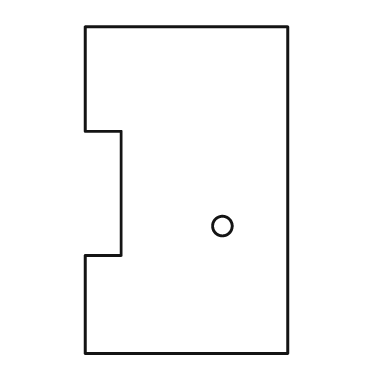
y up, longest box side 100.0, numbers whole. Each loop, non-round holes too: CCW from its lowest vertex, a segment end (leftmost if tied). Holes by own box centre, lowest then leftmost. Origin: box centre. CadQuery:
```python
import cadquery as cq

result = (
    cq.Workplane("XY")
    .moveTo(-31.0, -50.0)
    .lineTo(31.0, -50.0)
    .lineTo(31.0, 50.0)
    .lineTo(-31.0, 50.0)
    .lineTo(-31.0, 18.0)
    .lineTo(-20.0, 18.0)
    .lineTo(-20.0, -20.0)
    .lineTo(-31.0, -20.0)
    .close()
    .moveTo(11.0, -11.0)
    .circle(3.0)
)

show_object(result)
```